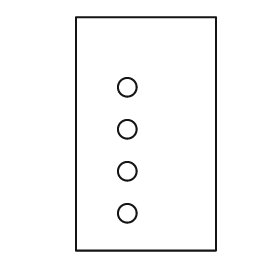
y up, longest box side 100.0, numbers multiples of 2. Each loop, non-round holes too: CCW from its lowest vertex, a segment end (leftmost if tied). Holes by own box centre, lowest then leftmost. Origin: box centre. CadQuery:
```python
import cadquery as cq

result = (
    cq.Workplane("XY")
    .moveTo(-30.0, -50.0)
    .lineTo(30.0, -50.0)
    .lineTo(30.0, 50.0)
    .lineTo(-30.0, 50.0)
    .close()
    .moveTo(-8.0, -34.0)
    .circle(4.0)
    .moveTo(-8.0, -16.0)
    .circle(4.0)
    .moveTo(-8.0, 2.0)
    .circle(4.0)
    .moveTo(-8.0, 20.0)
    .circle(4.0)
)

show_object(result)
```